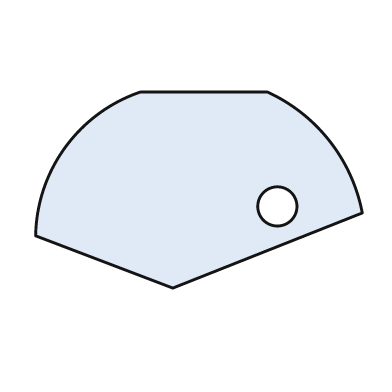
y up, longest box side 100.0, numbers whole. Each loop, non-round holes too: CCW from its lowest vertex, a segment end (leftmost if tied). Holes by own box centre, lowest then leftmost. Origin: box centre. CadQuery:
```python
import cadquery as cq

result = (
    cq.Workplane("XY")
    .moveTo(-8.0, -30.0)
    .lineTo(50.0, -7.0)
    .threePointArc((40.0, 15.0), (21.0, 30.0))
    .lineTo(-18.0, 30.0)
    .threePointArc((-41.0, 13.0), (-50.0, -14.0))
    .close()
    .moveTo(24.0, -5.0)
    .circle(6.0)
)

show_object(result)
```